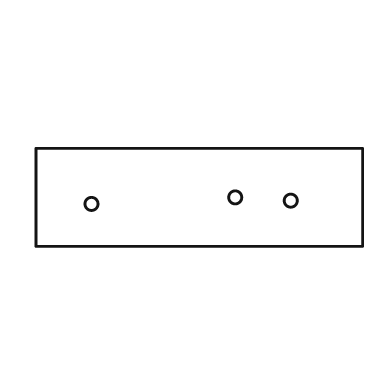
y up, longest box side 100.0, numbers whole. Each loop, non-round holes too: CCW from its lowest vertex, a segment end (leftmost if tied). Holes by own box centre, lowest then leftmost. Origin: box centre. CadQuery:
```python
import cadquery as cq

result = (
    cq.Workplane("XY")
    .moveTo(-50.0, -15.0)
    .lineTo(50.0, -15.0)
    .lineTo(50.0, 15.0)
    .lineTo(-50.0, 15.0)
    .close()
    .moveTo(-33.0, -2.0)
    .circle(2.0)
    .moveTo(28.0, -1.0)
    .circle(2.0)
    .moveTo(11.0, 0.0)
    .circle(2.0)
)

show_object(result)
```